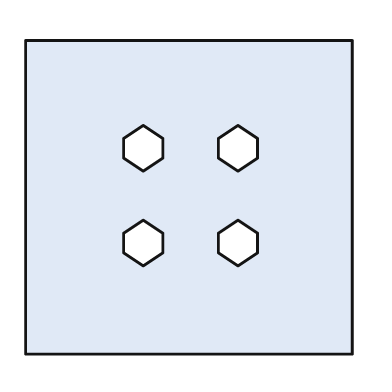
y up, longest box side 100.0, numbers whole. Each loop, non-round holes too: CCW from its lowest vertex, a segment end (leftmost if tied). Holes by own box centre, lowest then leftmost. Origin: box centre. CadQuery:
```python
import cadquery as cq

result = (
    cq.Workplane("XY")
    .moveTo(-50.0, -48.0)
    .lineTo(50.0, -48.0)
    .lineTo(50.0, 48.0)
    .lineTo(-50.0, 48.0)
    .close()
    .moveTo(-14.0, -21.0)
    .lineTo(-8.0, -17.0)
    .lineTo(-8.0, -11.0)
    .lineTo(-14.0, -7.0)
    .lineTo(-20.0, -11.0)
    .lineTo(-20.0, -17.0)
    .close()
    .moveTo(15.0, -21.0)
    .lineTo(21.0, -17.0)
    .lineTo(21.0, -11.0)
    .lineTo(15.0, -7.0)
    .lineTo(9.0, -11.0)
    .lineTo(9.0, -17.0)
    .close()
    .moveTo(-14.0, 8.0)
    .lineTo(-8.0, 12.0)
    .lineTo(-8.0, 18.0)
    .lineTo(-14.0, 22.0)
    .lineTo(-20.0, 18.0)
    .lineTo(-20.0, 12.0)
    .close()
    .moveTo(15.0, 8.0)
    .lineTo(21.0, 12.0)
    .lineTo(21.0, 18.0)
    .lineTo(15.0, 22.0)
    .lineTo(9.0, 18.0)
    .lineTo(9.0, 12.0)
    .close()
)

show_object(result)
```